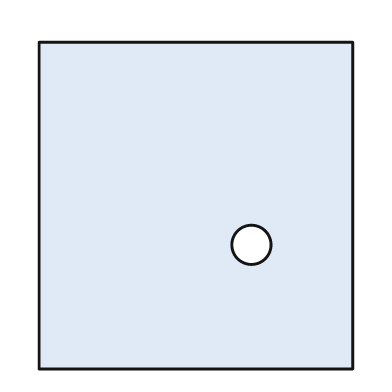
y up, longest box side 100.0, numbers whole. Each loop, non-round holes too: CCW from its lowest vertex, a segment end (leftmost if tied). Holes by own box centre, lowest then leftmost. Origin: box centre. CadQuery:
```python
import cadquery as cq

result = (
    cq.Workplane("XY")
    .moveTo(-48.0, -50.0)
    .lineTo(48.0, -50.0)
    .lineTo(48.0, 50.0)
    .lineTo(-48.0, 50.0)
    .close()
    .moveTo(17.0, -12.0)
    .circle(6.0)
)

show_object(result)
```